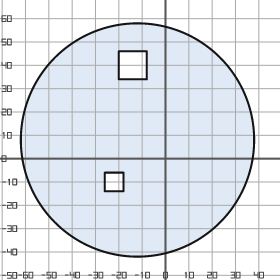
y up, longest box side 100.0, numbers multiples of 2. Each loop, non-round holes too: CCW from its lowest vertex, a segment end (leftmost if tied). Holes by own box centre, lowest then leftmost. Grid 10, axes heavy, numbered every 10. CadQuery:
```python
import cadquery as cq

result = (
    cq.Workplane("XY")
    .moveTo(-12.0, 8.0)
    .circle(50.0)
    .moveTo(-26.0, -14.0)
    .lineTo(-18.0, -14.0)
    .lineTo(-18.0, -6.0)
    .lineTo(-26.0, -6.0)
    .close()
    .moveTo(-20.0, 34.0)
    .lineTo(-8.0, 34.0)
    .lineTo(-8.0, 46.0)
    .lineTo(-20.0, 46.0)
    .close()
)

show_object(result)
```